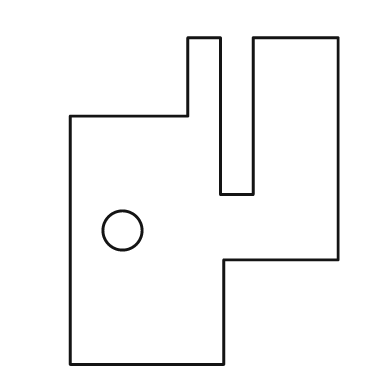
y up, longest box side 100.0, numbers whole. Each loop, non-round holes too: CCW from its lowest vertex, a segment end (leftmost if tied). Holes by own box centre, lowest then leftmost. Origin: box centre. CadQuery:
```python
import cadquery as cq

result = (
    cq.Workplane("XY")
    .moveTo(-41.0, -50.0)
    .lineTo(6.0, -50.0)
    .lineTo(6.0, -18.0)
    .lineTo(41.0, -18.0)
    .lineTo(41.0, 50.0)
    .lineTo(15.0, 50.0)
    .lineTo(15.0, 2.0)
    .lineTo(5.0, 2.0)
    .lineTo(5.0, 50.0)
    .lineTo(-5.0, 50.0)
    .lineTo(-5.0, 26.0)
    .lineTo(-41.0, 26.0)
    .close()
    .moveTo(-25.0, -9.0)
    .circle(6.0)
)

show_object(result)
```